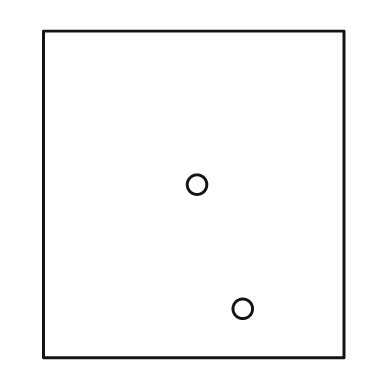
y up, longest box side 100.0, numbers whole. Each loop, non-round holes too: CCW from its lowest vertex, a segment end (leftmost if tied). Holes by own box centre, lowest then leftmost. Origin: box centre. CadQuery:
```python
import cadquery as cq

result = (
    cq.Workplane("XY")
    .moveTo(-46.0, -50.0)
    .lineTo(46.0, -50.0)
    .lineTo(46.0, 50.0)
    .lineTo(-46.0, 50.0)
    .close()
    .moveTo(15.0, -35.0)
    .circle(3.0)
    .moveTo(1.0, 3.0)
    .circle(3.0)
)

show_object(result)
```